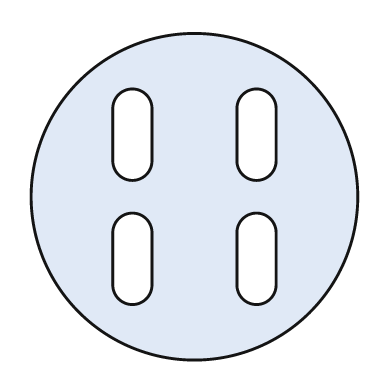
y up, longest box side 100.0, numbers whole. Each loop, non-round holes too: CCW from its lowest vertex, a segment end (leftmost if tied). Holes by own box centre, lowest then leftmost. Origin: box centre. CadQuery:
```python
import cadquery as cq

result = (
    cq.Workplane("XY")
    .moveTo(0.0, 0.0)
    .circle(50.0)
    .moveTo(-25.0, -27.0)
    .threePointArc((-19.0, -33.0), (-13.0, -27.0))
    .lineTo(-13.0, -11.0)
    .threePointArc((-19.0, -5.0), (-25.0, -11.0))
    .close()
    .moveTo(13.0, -27.0)
    .threePointArc((19.0, -33.0), (25.0, -27.0))
    .lineTo(25.0, -11.0)
    .threePointArc((19.0, -5.0), (13.0, -11.0))
    .close()
    .moveTo(-25.0, 11.0)
    .threePointArc((-19.0, 5.0), (-13.0, 11.0))
    .lineTo(-13.0, 27.0)
    .threePointArc((-19.0, 33.0), (-25.0, 27.0))
    .close()
    .moveTo(13.0, 11.0)
    .threePointArc((19.0, 5.0), (25.0, 11.0))
    .lineTo(25.0, 27.0)
    .threePointArc((19.0, 33.0), (13.0, 27.0))
    .close()
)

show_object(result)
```